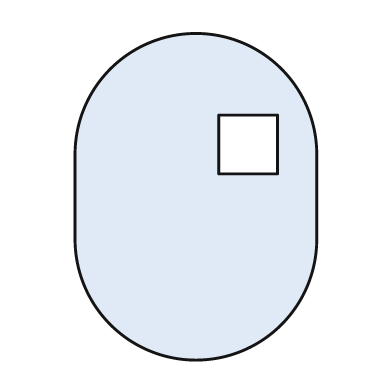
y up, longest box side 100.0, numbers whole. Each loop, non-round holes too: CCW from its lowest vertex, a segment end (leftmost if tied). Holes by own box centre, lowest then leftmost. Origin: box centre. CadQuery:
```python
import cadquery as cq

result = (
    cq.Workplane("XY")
    .moveTo(-37.0, -13.0)
    .threePointArc((0.0, -50.0), (37.0, -13.0))
    .lineTo(37.0, 13.0)
    .threePointArc((0.0, 50.0), (-37.0, 13.0))
    .close()
    .moveTo(7.0, 7.0)
    .lineTo(25.0, 7.0)
    .lineTo(25.0, 25.0)
    .lineTo(7.0, 25.0)
    .close()
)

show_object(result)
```